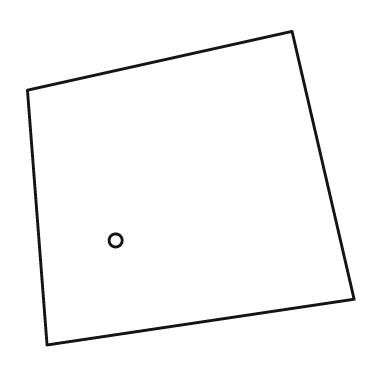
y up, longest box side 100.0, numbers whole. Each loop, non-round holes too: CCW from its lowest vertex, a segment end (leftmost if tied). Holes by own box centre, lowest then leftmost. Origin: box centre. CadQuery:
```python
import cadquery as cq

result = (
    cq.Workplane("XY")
    .moveTo(-44.0, -48.0)
    .lineTo(50.0, -34.0)
    .lineTo(31.0, 48.0)
    .lineTo(-50.0, 30.0)
    .close()
    .moveTo(-23.0, -16.0)
    .circle(2.0)
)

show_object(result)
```